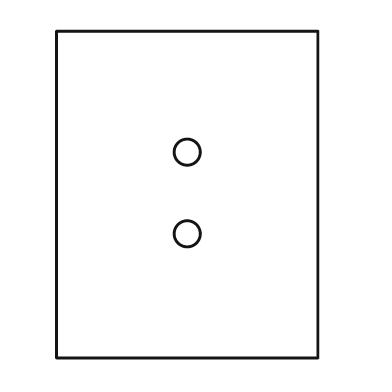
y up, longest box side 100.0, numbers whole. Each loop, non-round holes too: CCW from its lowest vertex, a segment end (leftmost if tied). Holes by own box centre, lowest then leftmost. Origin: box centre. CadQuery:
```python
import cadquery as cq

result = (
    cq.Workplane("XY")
    .moveTo(-40.0, -50.0)
    .lineTo(40.0, -50.0)
    .lineTo(40.0, 50.0)
    .lineTo(-40.0, 50.0)
    .close()
    .moveTo(0.0, -12.0)
    .circle(4.0)
    .moveTo(0.0, 13.0)
    .circle(4.0)
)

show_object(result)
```